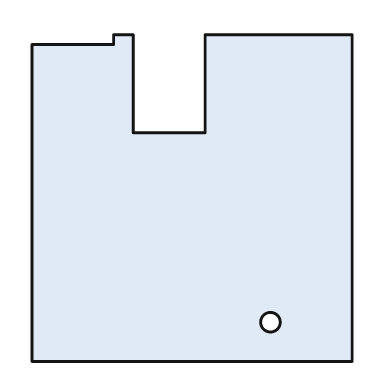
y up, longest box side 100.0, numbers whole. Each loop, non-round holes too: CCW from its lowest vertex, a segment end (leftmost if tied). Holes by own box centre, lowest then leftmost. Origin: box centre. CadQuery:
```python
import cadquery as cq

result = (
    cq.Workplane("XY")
    .moveTo(-49.0, -50.0)
    .lineTo(49.0, -50.0)
    .lineTo(49.0, 50.0)
    .lineTo(4.0, 50.0)
    .lineTo(4.0, 20.0)
    .lineTo(-18.0, 20.0)
    .lineTo(-18.0, 50.0)
    .lineTo(-24.0, 50.0)
    .lineTo(-24.0, 47.0)
    .lineTo(-49.0, 47.0)
    .close()
    .moveTo(24.0, -38.0)
    .circle(3.0)
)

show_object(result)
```